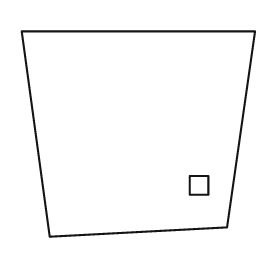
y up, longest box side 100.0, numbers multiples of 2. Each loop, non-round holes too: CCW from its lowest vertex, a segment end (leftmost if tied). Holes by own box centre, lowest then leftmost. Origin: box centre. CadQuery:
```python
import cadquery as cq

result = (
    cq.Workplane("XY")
    .moveTo(-38.0, -44.0)
    .lineTo(38.0, -40.0)
    .lineTo(50.0, 44.0)
    .lineTo(-50.0, 44.0)
    .close()
    .moveTo(22.0, -26.0)
    .lineTo(30.0, -26.0)
    .lineTo(30.0, -18.0)
    .lineTo(22.0, -18.0)
    .close()
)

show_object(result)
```